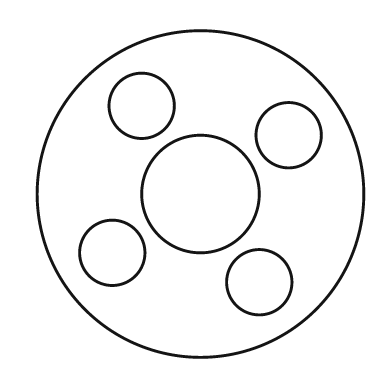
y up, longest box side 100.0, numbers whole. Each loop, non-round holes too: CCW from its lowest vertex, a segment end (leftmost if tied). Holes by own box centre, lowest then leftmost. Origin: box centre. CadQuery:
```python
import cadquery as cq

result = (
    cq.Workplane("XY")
    .moveTo(0.0, 0.0)
    .circle(50.0)
    .moveTo(18.0, -27.0)
    .circle(10.0)
    .moveTo(-27.0, -18.0)
    .circle(10.0)
    .moveTo(0.0, 0.0)
    .circle(18.0)
    .moveTo(27.0, 18.0)
    .circle(10.0)
    .moveTo(-18.0, 27.0)
    .circle(10.0)
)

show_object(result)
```